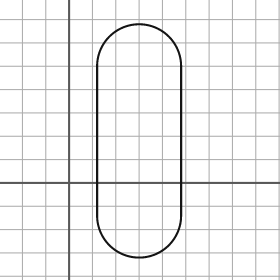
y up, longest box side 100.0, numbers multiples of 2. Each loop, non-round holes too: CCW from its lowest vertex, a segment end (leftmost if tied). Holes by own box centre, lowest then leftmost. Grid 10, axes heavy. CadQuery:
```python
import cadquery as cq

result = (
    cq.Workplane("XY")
    .moveTo(12.0, -14.0)
    .threePointArc((30.0, -32.0), (48.0, -14.0))
    .lineTo(48.0, 50.0)
    .threePointArc((30.0, 68.0), (12.0, 50.0))
    .close()
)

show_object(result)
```